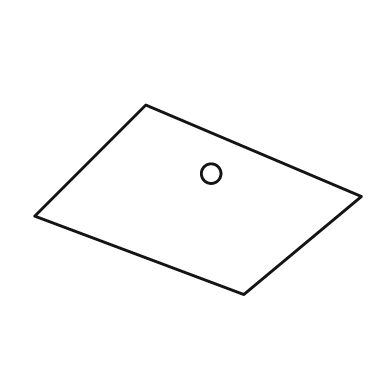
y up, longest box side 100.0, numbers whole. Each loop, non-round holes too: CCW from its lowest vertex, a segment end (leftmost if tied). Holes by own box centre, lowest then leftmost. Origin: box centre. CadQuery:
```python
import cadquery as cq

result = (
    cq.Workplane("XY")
    .moveTo(14.0, -29.0)
    .lineTo(50.0, 1.0)
    .lineTo(-16.0, 29.0)
    .lineTo(-50.0, -5.0)
    .close()
    .moveTo(4.0, 8.0)
    .circle(3.0)
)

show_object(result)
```